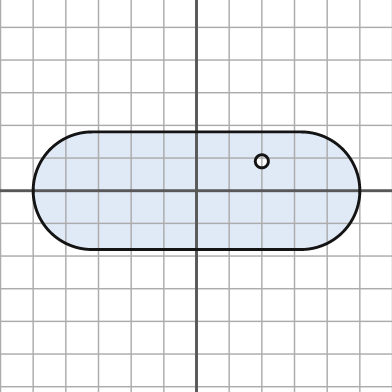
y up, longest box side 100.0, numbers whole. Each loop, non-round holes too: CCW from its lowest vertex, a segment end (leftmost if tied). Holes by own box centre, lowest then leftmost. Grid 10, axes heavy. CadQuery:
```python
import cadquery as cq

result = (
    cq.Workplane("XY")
    .moveTo(-32.0, -18.0)
    .lineTo(32.0, -18.0)
    .threePointArc((50.0, 0.0), (32.0, 18.0))
    .lineTo(-32.0, 18.0)
    .threePointArc((-50.0, 0.0), (-32.0, -18.0))
    .close()
    .moveTo(20.0, 9.0)
    .circle(2.0)
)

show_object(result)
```